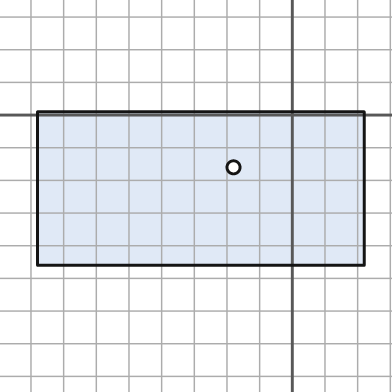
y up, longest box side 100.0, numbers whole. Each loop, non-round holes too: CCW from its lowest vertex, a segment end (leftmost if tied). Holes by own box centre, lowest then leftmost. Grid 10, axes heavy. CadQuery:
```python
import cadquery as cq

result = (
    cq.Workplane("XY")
    .moveTo(-78.0, -46.0)
    .lineTo(22.0, -46.0)
    .lineTo(22.0, 1.0)
    .lineTo(-78.0, 1.0)
    .close()
    .moveTo(-18.0, -16.0)
    .circle(2.0)
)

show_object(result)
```